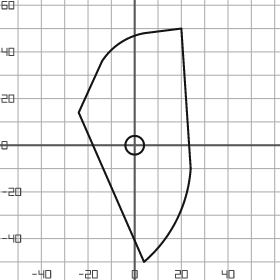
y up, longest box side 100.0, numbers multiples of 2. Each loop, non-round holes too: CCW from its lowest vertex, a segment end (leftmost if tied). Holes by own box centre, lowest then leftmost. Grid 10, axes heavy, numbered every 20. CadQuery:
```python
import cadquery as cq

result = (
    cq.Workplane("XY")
    .moveTo(4.0, -50.0)
    .threePointArc((18.0, -32.0), (24.0, -10.0))
    .lineTo(20.0, 50.0)
    .lineTo(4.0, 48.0)
    .threePointArc((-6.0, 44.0), (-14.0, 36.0))
    .lineTo(-24.0, 14.0)
    .close()
    .moveTo(0.0, 0.0)
    .circle(4.0)
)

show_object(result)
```